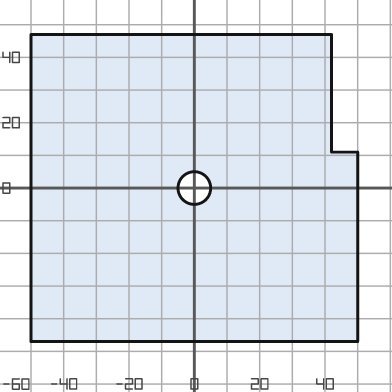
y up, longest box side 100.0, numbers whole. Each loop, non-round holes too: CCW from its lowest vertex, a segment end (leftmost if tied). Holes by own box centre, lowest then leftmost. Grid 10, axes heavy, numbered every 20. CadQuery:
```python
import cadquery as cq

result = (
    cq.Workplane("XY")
    .moveTo(-50.0, -47.0)
    .lineTo(50.0, -47.0)
    .lineTo(50.0, 11.0)
    .lineTo(42.0, 11.0)
    .lineTo(42.0, 47.0)
    .lineTo(-50.0, 47.0)
    .close()
    .moveTo(0.0, 0.0)
    .circle(5.0)
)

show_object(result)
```